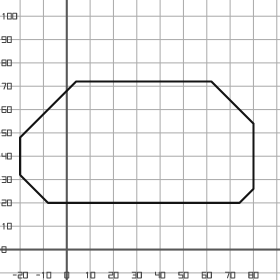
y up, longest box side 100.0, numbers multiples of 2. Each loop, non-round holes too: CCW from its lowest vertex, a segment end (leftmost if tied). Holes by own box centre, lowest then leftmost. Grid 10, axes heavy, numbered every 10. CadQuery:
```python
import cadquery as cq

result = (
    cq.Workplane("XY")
    .moveTo(-8.0, 20.0)
    .lineTo(74.0, 20.0)
    .lineTo(80.0, 26.0)
    .lineTo(80.0, 54.0)
    .lineTo(62.0, 72.0)
    .lineTo(4.0, 72.0)
    .lineTo(-20.0, 48.0)
    .lineTo(-20.0, 32.0)
    .close()
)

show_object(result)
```